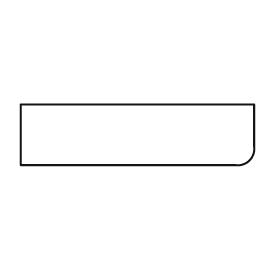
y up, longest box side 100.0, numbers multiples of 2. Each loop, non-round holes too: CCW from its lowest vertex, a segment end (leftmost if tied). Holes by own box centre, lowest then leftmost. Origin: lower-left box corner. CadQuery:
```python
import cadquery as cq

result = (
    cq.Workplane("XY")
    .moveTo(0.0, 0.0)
    .lineTo(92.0, 0.0)
    .threePointArc((98.0, 2.0), (100.0, 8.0))
    .lineTo(100.0, 26.0)
    .lineTo(0.0, 26.0)
    .close()
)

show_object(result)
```